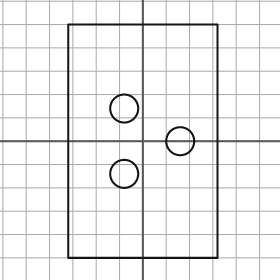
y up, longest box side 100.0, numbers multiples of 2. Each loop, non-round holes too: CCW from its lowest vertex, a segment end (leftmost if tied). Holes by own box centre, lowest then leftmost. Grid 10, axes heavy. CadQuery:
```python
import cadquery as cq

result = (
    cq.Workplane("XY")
    .moveTo(-32.0, -50.0)
    .lineTo(32.0, -50.0)
    .lineTo(32.0, 50.0)
    .lineTo(-32.0, 50.0)
    .close()
    .moveTo(-8.0, -14.0)
    .circle(6.0)
    .moveTo(16.0, 0.0)
    .circle(6.0)
    .moveTo(-8.0, 14.0)
    .circle(6.0)
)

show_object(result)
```